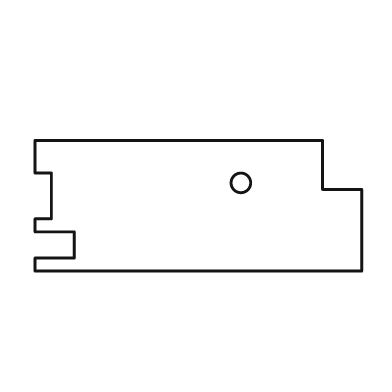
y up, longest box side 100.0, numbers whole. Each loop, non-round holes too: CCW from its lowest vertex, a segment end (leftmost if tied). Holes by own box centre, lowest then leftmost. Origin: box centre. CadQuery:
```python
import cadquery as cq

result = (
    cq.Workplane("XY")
    .moveTo(-50.0, -20.0)
    .lineTo(50.0, -20.0)
    .lineTo(50.0, 5.0)
    .lineTo(38.0, 5.0)
    .lineTo(38.0, 20.0)
    .lineTo(-50.0, 20.0)
    .lineTo(-50.0, 10.0)
    .lineTo(-45.0, 10.0)
    .lineTo(-45.0, -4.0)
    .lineTo(-50.0, -4.0)
    .lineTo(-50.0, -8.0)
    .lineTo(-38.0, -8.0)
    .lineTo(-38.0, -16.0)
    .lineTo(-50.0, -16.0)
    .close()
    .moveTo(13.0, 7.0)
    .circle(3.0)
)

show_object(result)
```